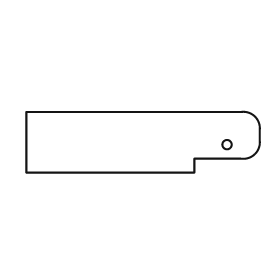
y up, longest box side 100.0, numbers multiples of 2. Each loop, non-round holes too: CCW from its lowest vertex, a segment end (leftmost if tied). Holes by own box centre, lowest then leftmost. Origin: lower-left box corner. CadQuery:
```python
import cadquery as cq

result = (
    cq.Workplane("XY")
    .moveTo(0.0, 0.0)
    .lineTo(72.0, 0.0)
    .lineTo(72.0, 6.0)
    .lineTo(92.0, 6.0)
    .threePointArc((98.0, 8.0), (100.0, 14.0))
    .lineTo(100.0, 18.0)
    .threePointArc((98.0, 24.0), (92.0, 26.0))
    .lineTo(0.0, 26.0)
    .close()
    .moveTo(86.0, 12.0)
    .circle(2.0)
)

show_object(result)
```